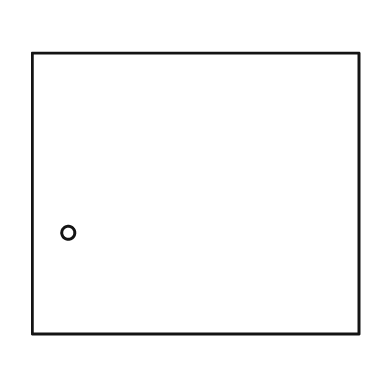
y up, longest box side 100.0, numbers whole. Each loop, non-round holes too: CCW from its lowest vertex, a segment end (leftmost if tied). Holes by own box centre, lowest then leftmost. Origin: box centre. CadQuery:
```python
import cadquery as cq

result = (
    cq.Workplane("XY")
    .moveTo(-50.0, -43.0)
    .lineTo(50.0, -43.0)
    .lineTo(50.0, 43.0)
    .lineTo(-50.0, 43.0)
    .close()
    .moveTo(-39.0, -12.0)
    .circle(2.0)
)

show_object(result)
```